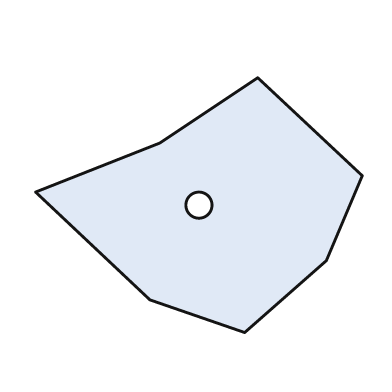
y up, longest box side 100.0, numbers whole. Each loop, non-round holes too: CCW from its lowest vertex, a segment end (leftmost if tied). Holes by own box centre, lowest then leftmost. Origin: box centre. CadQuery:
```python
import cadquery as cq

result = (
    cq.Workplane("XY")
    .moveTo(14.0, -39.0)
    .lineTo(39.0, -17.0)
    .lineTo(50.0, 9.0)
    .lineTo(18.0, 39.0)
    .lineTo(-12.0, 19.0)
    .lineTo(-50.0, 4.0)
    .lineTo(-15.0, -29.0)
    .close()
    .moveTo(0.0, 0.0)
    .circle(4.0)
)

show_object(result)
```